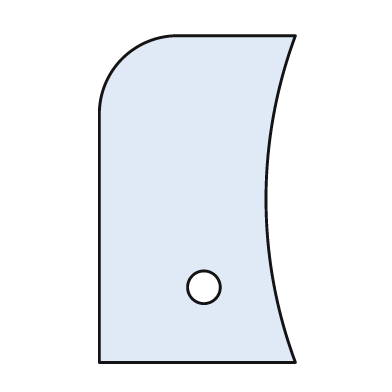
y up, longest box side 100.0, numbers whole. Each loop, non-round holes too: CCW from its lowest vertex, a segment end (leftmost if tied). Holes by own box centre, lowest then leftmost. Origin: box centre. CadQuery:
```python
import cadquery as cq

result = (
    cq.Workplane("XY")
    .moveTo(-30.0, -50.0)
    .lineTo(30.0, -50.0)
    .threePointArc((21.0, 0.0), (30.0, 50.0))
    .lineTo(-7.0, 50.0)
    .threePointArc((-23.0, 43.0), (-30.0, 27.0))
    .close()
    .moveTo(2.0, -27.0)
    .circle(5.0)
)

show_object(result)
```